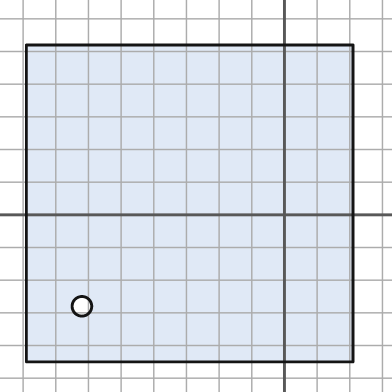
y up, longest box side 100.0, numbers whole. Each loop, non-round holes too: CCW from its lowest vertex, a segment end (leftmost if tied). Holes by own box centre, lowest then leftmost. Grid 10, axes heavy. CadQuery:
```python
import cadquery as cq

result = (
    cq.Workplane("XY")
    .moveTo(-79.0, -45.0)
    .lineTo(21.0, -45.0)
    .lineTo(21.0, 52.0)
    .lineTo(-79.0, 52.0)
    .close()
    .moveTo(-62.0, -28.0)
    .circle(3.0)
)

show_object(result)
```